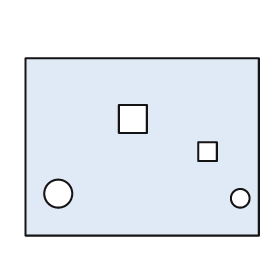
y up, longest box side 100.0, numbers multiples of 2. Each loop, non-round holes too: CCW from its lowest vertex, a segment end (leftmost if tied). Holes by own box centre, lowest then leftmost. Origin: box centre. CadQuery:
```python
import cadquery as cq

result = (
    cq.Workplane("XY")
    .moveTo(-50.0, -38.0)
    .lineTo(50.0, -38.0)
    .lineTo(50.0, 38.0)
    .lineTo(-50.0, 38.0)
    .close()
    .moveTo(42.0, -22.0)
    .circle(4.0)
    .moveTo(-36.0, -20.0)
    .circle(6.0)
    .moveTo(24.0, -6.0)
    .lineTo(32.0, -6.0)
    .lineTo(32.0, 2.0)
    .lineTo(24.0, 2.0)
    .close()
    .moveTo(-10.0, 6.0)
    .lineTo(2.0, 6.0)
    .lineTo(2.0, 18.0)
    .lineTo(-10.0, 18.0)
    .close()
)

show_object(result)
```